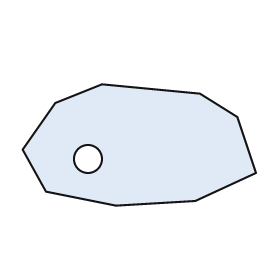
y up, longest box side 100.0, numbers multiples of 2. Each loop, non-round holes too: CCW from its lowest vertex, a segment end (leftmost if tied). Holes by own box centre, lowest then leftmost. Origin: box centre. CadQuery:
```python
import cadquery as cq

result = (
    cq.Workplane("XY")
    .moveTo(-10.0, -26.0)
    .lineTo(24.0, -24.0)
    .lineTo(50.0, -12.0)
    .lineTo(42.0, 12.0)
    .lineTo(26.0, 22.0)
    .lineTo(-16.0, 26.0)
    .lineTo(-36.0, 18.0)
    .lineTo(-50.0, -2.0)
    .lineTo(-40.0, -20.0)
    .close()
    .moveTo(-22.0, -6.0)
    .circle(6.0)
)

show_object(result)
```